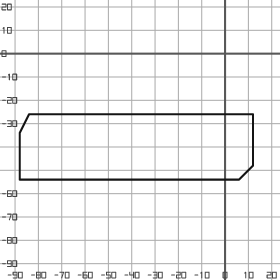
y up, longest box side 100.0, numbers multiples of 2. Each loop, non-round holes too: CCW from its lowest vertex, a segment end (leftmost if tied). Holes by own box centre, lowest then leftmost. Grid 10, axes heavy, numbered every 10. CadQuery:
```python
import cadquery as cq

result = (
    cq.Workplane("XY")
    .moveTo(-88.0, -54.0)
    .lineTo(6.0, -54.0)
    .lineTo(12.0, -48.0)
    .lineTo(12.0, -26.0)
    .lineTo(-84.0, -26.0)
    .lineTo(-88.0, -34.0)
    .close()
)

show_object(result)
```